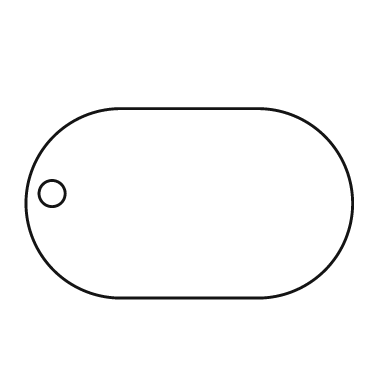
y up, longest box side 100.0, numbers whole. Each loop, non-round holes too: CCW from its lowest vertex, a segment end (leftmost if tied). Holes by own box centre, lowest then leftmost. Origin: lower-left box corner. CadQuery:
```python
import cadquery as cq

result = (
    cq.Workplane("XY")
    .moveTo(29.0, 0.0)
    .lineTo(71.0, 0.0)
    .threePointArc((100.0, 29.0), (71.0, 58.0))
    .lineTo(29.0, 58.0)
    .threePointArc((0.0, 29.0), (29.0, 0.0))
    .close()
    .moveTo(8.0, 32.0)
    .circle(4.0)
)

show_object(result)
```